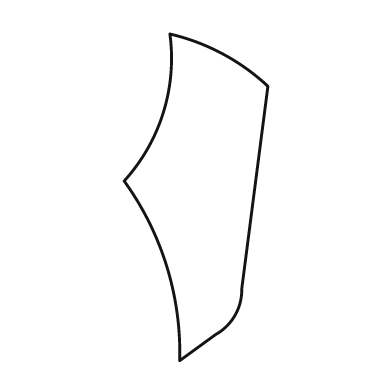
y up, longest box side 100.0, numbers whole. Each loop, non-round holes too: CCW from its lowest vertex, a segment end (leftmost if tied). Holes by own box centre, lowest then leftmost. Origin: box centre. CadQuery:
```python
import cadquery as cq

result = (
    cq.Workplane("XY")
    .moveTo(-5.0, -50.0)
    .lineTo(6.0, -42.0)
    .threePointArc((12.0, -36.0), (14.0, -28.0))
    .lineTo(22.0, 34.0)
    .threePointArc((8.0, 44.0), (-8.0, 50.0))
    .threePointArc((-10.0, 26.0), (-22.0, 5.0))
    .threePointArc((-9.0, -21.0), (-5.0, -50.0))
    .close()
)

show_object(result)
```